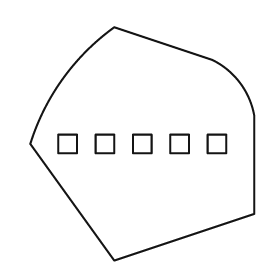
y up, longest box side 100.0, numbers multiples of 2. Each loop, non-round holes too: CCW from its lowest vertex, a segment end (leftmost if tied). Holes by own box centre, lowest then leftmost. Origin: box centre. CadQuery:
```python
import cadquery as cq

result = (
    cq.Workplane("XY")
    .moveTo(-12.0, -50.0)
    .lineTo(48.0, -30.0)
    .lineTo(48.0, 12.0)
    .threePointArc((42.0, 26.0), (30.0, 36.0))
    .lineTo(-12.0, 50.0)
    .threePointArc((-34.0, 28.0), (-48.0, 0.0))
    .close()
    .moveTo(-36.0, -4.0)
    .lineTo(-28.0, -4.0)
    .lineTo(-28.0, 4.0)
    .lineTo(-36.0, 4.0)
    .close()
    .moveTo(-20.0, -4.0)
    .lineTo(-12.0, -4.0)
    .lineTo(-12.0, 4.0)
    .lineTo(-20.0, 4.0)
    .close()
    .moveTo(-4.0, -4.0)
    .lineTo(4.0, -4.0)
    .lineTo(4.0, 4.0)
    .lineTo(-4.0, 4.0)
    .close()
    .moveTo(12.0, -4.0)
    .lineTo(20.0, -4.0)
    .lineTo(20.0, 4.0)
    .lineTo(12.0, 4.0)
    .close()
    .moveTo(28.0, -4.0)
    .lineTo(36.0, -4.0)
    .lineTo(36.0, 4.0)
    .lineTo(28.0, 4.0)
    .close()
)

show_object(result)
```